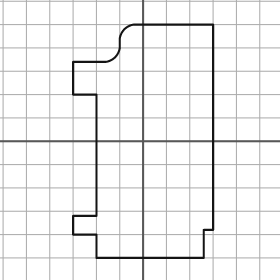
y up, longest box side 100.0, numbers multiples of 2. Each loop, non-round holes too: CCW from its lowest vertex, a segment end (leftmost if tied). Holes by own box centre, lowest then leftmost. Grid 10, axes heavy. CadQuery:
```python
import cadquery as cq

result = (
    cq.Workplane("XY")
    .moveTo(-20.0, -50.0)
    .lineTo(26.0, -50.0)
    .lineTo(26.0, -38.0)
    .lineTo(30.0, -38.0)
    .lineTo(30.0, 50.0)
    .lineTo(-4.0, 50.0)
    .threePointArc((-8.0, 48.0), (-10.0, 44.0))
    .lineTo(-10.0, 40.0)
    .threePointArc((-12.0, 36.0), (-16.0, 34.0))
    .lineTo(-30.0, 34.0)
    .lineTo(-30.0, 20.0)
    .lineTo(-20.0, 20.0)
    .lineTo(-20.0, -32.0)
    .lineTo(-30.0, -32.0)
    .lineTo(-30.0, -40.0)
    .lineTo(-20.0, -40.0)
    .close()
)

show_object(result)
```